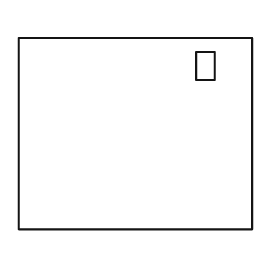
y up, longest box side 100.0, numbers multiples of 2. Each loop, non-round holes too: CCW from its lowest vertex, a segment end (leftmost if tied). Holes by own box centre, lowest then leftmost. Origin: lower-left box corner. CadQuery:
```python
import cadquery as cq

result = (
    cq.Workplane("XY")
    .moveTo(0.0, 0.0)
    .lineTo(100.0, 0.0)
    .lineTo(100.0, 82.0)
    .lineTo(0.0, 82.0)
    .close()
    .moveTo(76.0, 64.0)
    .lineTo(84.0, 64.0)
    .lineTo(84.0, 76.0)
    .lineTo(76.0, 76.0)
    .close()
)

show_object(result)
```